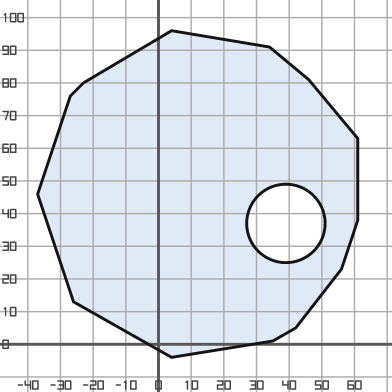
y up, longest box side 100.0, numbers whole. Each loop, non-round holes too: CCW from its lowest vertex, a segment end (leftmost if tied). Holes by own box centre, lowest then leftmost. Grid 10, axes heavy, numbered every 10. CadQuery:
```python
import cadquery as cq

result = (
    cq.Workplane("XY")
    .moveTo(4.0, -4.0)
    .lineTo(35.0, 1.0)
    .lineTo(42.0, 5.0)
    .lineTo(56.0, 23.0)
    .lineTo(61.0, 38.0)
    .lineTo(61.0, 63.0)
    .lineTo(46.0, 81.0)
    .lineTo(34.0, 91.0)
    .lineTo(4.0, 96.0)
    .lineTo(-23.0, 80.0)
    .lineTo(-27.0, 76.0)
    .lineTo(-37.0, 46.0)
    .lineTo(-26.0, 13.0)
    .close()
    .moveTo(39.0, 37.0)
    .circle(12.0)
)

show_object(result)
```